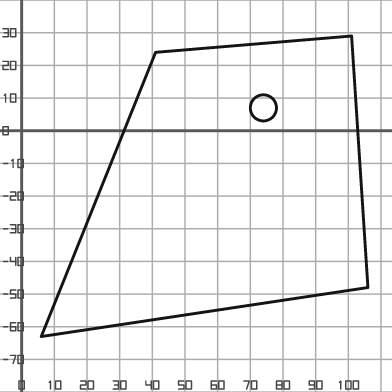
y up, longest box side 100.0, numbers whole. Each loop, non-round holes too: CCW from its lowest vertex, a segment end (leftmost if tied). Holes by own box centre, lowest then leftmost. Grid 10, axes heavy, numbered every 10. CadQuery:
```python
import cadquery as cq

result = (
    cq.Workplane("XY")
    .moveTo(6.0, -63.0)
    .lineTo(106.0, -48.0)
    .lineTo(101.0, 29.0)
    .lineTo(41.0, 24.0)
    .close()
    .moveTo(74.0, 7.0)
    .circle(4.0)
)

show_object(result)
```